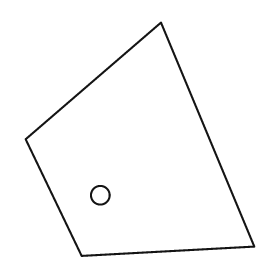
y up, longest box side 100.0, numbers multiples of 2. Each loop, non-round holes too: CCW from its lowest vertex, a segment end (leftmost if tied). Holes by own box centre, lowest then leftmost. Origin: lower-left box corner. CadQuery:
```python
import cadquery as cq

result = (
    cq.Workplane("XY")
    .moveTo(24.0, 0.0)
    .lineTo(98.0, 4.0)
    .lineTo(58.0, 100.0)
    .lineTo(0.0, 50.0)
    .close()
    .moveTo(32.0, 26.0)
    .circle(4.0)
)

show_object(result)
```